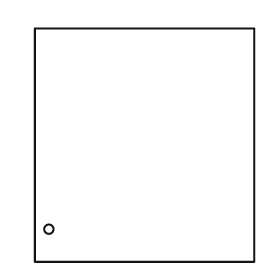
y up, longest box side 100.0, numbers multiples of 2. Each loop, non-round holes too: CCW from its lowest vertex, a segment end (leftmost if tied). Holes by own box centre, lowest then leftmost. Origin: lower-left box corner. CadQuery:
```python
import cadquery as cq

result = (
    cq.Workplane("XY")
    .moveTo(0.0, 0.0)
    .lineTo(94.0, 0.0)
    .lineTo(94.0, 100.0)
    .lineTo(0.0, 100.0)
    .close()
    .moveTo(6.0, 14.0)
    .circle(2.0)
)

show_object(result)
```